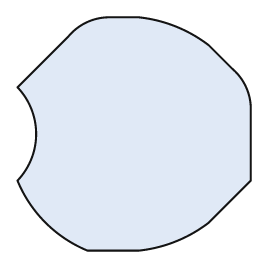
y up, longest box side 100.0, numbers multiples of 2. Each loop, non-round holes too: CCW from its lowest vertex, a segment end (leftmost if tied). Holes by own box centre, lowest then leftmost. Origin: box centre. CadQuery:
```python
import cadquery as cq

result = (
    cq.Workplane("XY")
    .moveTo(-20.0, -50.0)
    .lineTo(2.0, -50.0)
    .threePointArc((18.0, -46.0), (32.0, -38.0))
    .lineTo(50.0, -20.0)
    .lineTo(50.0, 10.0)
    .threePointArc((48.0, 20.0), (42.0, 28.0))
    .lineTo(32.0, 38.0)
    .threePointArc((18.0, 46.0), (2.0, 50.0))
    .lineTo(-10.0, 50.0)
    .threePointArc((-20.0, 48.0), (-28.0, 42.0))
    .lineTo(-50.0, 20.0)
    .threePointArc((-42.0, 0.0), (-50.0, -20.0))
    .threePointArc((-38.0, -38.0), (-20.0, -50.0))
    .close()
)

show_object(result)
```